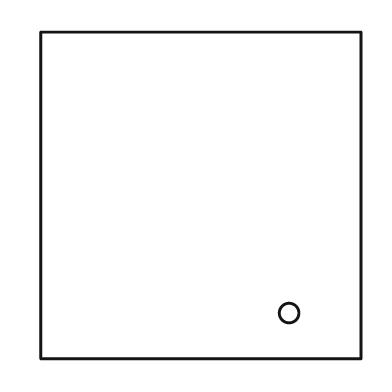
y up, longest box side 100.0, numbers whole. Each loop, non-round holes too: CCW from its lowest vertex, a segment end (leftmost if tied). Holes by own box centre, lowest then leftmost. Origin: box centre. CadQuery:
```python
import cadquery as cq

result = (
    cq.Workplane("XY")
    .moveTo(-49.0, -50.0)
    .lineTo(49.0, -50.0)
    .lineTo(49.0, 50.0)
    .lineTo(-49.0, 50.0)
    .close()
    .moveTo(27.0, -36.0)
    .circle(3.0)
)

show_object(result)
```